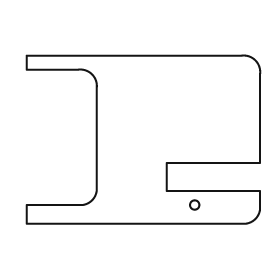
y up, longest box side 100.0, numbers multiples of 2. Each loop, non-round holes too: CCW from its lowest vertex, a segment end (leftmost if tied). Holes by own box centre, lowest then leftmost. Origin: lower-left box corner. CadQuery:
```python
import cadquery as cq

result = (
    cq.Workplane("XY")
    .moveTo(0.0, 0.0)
    .lineTo(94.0, 0.0)
    .threePointArc((98.0, 2.0), (100.0, 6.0))
    .lineTo(100.0, 14.0)
    .lineTo(60.0, 14.0)
    .lineTo(60.0, 26.0)
    .lineTo(100.0, 26.0)
    .lineTo(100.0, 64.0)
    .threePointArc((98.0, 70.0), (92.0, 72.0))
    .lineTo(0.0, 72.0)
    .lineTo(0.0, 66.0)
    .lineTo(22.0, 66.0)
    .threePointArc((28.0, 64.0), (30.0, 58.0))
    .lineTo(30.0, 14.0)
    .threePointArc((28.0, 10.0), (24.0, 8.0))
    .lineTo(0.0, 8.0)
    .close()
    .moveTo(72.0, 8.0)
    .circle(2.0)
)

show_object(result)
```